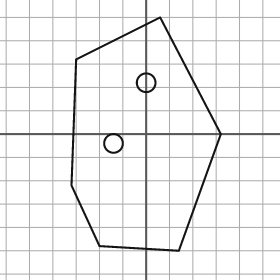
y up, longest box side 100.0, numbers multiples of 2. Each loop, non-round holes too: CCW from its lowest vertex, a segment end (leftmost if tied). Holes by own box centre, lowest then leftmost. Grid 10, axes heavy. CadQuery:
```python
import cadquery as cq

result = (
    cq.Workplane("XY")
    .moveTo(14.0, -50.0)
    .lineTo(32.0, 0.0)
    .lineTo(6.0, 50.0)
    .lineTo(-30.0, 32.0)
    .lineTo(-32.0, -22.0)
    .lineTo(-20.0, -48.0)
    .close()
    .moveTo(-14.0, -4.0)
    .circle(4.0)
    .moveTo(0.0, 22.0)
    .circle(4.0)
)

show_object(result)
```